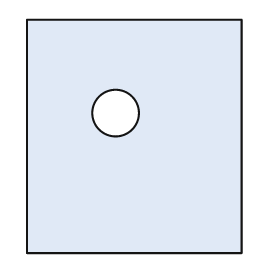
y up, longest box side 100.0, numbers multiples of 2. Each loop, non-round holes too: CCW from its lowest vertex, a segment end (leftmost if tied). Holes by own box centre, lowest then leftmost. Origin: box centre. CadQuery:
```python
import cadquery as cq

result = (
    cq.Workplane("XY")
    .moveTo(-46.0, -50.0)
    .lineTo(46.0, -50.0)
    .lineTo(46.0, 50.0)
    .lineTo(-46.0, 50.0)
    .close()
    .moveTo(-8.0, 10.0)
    .circle(10.0)
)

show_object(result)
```